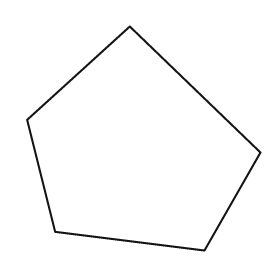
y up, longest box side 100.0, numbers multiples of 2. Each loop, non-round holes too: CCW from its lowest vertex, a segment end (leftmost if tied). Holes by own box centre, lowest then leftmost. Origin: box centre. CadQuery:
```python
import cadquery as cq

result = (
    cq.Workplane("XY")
    .moveTo(26.0, -48.0)
    .lineTo(50.0, -6.0)
    .lineTo(-6.0, 48.0)
    .lineTo(-50.0, 8.0)
    .lineTo(-38.0, -40.0)
    .close()
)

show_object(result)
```